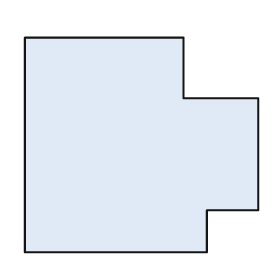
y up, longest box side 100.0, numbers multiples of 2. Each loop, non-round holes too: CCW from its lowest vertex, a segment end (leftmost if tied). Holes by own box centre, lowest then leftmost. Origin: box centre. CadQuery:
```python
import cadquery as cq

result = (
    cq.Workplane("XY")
    .moveTo(-50.0, -46.0)
    .lineTo(28.0, -46.0)
    .lineTo(28.0, -28.0)
    .lineTo(50.0, -28.0)
    .lineTo(50.0, 20.0)
    .lineTo(18.0, 20.0)
    .lineTo(18.0, 46.0)
    .lineTo(-50.0, 46.0)
    .close()
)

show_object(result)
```